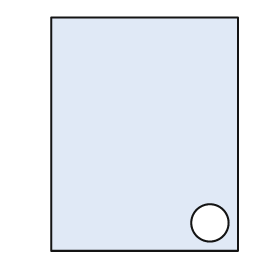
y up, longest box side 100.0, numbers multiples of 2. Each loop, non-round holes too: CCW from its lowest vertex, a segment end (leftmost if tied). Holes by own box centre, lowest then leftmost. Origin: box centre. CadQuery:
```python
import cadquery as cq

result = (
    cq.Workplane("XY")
    .moveTo(-40.0, -50.0)
    .lineTo(40.0, -50.0)
    .lineTo(40.0, 50.0)
    .lineTo(-40.0, 50.0)
    .close()
    .moveTo(28.0, -38.0)
    .circle(8.0)
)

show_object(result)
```